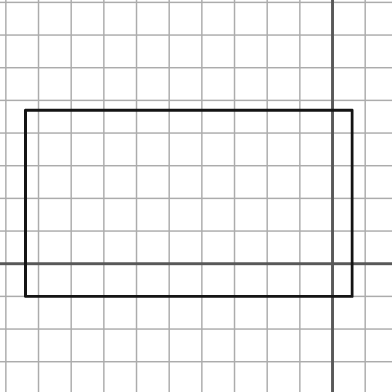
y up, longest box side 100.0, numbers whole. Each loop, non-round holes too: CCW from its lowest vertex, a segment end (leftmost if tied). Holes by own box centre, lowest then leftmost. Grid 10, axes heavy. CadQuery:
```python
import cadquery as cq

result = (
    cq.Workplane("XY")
    .moveTo(-94.0, -10.0)
    .lineTo(6.0, -10.0)
    .lineTo(6.0, 47.0)
    .lineTo(-94.0, 47.0)
    .close()
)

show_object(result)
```